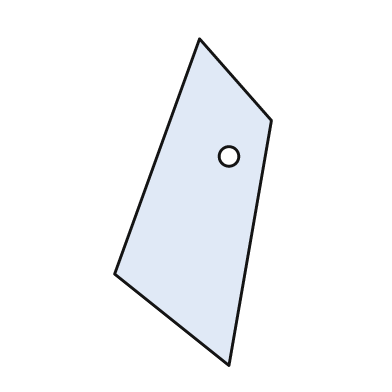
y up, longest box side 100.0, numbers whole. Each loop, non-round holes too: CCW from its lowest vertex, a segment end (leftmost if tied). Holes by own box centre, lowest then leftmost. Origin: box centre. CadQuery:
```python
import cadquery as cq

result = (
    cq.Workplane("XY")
    .moveTo(11.0, -50.0)
    .lineTo(24.0, 25.0)
    .lineTo(2.0, 50.0)
    .lineTo(-24.0, -22.0)
    .close()
    .moveTo(11.0, 14.0)
    .circle(3.0)
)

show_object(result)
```